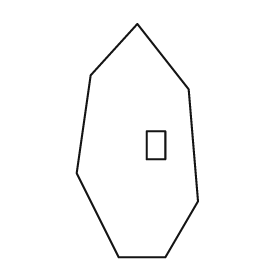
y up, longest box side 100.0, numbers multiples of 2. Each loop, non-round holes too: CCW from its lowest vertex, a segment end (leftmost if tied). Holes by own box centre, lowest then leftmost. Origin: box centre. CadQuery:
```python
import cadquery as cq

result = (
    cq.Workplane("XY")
    .moveTo(-8.0, -50.0)
    .lineTo(12.0, -50.0)
    .lineTo(26.0, -26.0)
    .lineTo(22.0, 22.0)
    .lineTo(0.0, 50.0)
    .lineTo(-20.0, 28.0)
    .lineTo(-26.0, -14.0)
    .close()
    .moveTo(4.0, -8.0)
    .lineTo(12.0, -8.0)
    .lineTo(12.0, 4.0)
    .lineTo(4.0, 4.0)
    .close()
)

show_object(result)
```